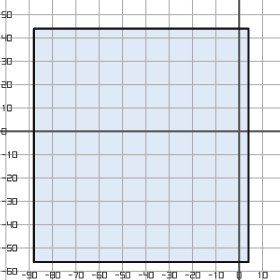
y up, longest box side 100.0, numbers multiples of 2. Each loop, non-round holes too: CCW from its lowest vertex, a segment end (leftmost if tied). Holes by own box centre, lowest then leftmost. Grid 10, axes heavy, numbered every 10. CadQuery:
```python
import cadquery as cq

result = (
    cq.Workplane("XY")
    .moveTo(-88.0, -56.0)
    .lineTo(4.0, -56.0)
    .lineTo(4.0, 44.0)
    .lineTo(-88.0, 44.0)
    .close()
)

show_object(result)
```